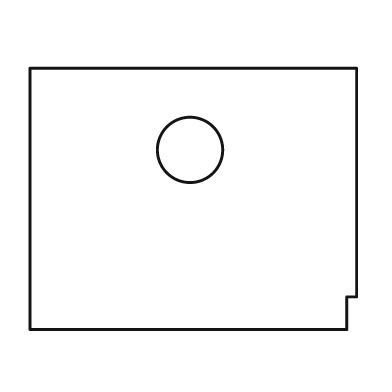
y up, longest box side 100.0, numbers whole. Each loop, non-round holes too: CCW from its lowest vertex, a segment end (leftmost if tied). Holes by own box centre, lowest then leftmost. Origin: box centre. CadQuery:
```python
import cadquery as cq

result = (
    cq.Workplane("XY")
    .moveTo(-50.0, -40.0)
    .lineTo(47.0, -40.0)
    .lineTo(47.0, -30.0)
    .lineTo(50.0, -30.0)
    .lineTo(50.0, 40.0)
    .lineTo(-50.0, 40.0)
    .close()
    .moveTo(-1.0, 15.0)
    .circle(10.0)
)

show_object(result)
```